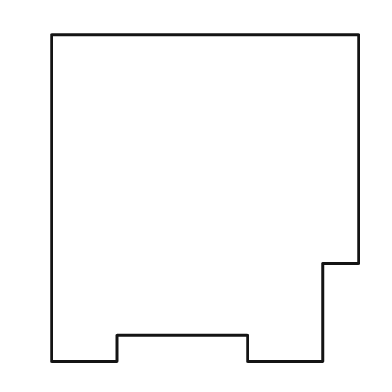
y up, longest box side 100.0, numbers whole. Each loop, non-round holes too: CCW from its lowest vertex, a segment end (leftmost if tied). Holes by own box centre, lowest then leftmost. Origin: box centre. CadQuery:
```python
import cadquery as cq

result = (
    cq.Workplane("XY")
    .moveTo(-47.0, -50.0)
    .lineTo(-27.0, -50.0)
    .lineTo(-27.0, -42.0)
    .lineTo(13.0, -42.0)
    .lineTo(13.0, -50.0)
    .lineTo(36.0, -50.0)
    .lineTo(36.0, -20.0)
    .lineTo(47.0, -20.0)
    .lineTo(47.0, 50.0)
    .lineTo(-47.0, 50.0)
    .close()
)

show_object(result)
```